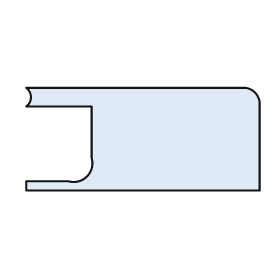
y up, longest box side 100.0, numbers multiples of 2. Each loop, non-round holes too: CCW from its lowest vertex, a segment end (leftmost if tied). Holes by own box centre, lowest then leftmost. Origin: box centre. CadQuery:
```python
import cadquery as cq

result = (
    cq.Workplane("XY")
    .moveTo(-50.0, -22.0)
    .lineTo(50.0, -22.0)
    .lineTo(50.0, 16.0)
    .threePointArc((48.0, 20.0), (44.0, 22.0))
    .lineTo(-50.0, 22.0)
    .threePointArc((-48.0, 18.0), (-50.0, 14.0))
    .lineTo(-22.0, 14.0)
    .lineTo(-22.0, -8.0)
    .threePointArc((-24.0, -16.0), (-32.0, -18.0))
    .lineTo(-50.0, -18.0)
    .close()
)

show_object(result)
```